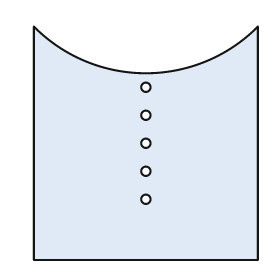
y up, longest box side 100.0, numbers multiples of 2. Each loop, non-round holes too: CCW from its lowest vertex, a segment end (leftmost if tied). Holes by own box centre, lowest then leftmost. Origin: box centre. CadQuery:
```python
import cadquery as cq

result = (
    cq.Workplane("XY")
    .moveTo(-48.0, -50.0)
    .lineTo(48.0, -50.0)
    .lineTo(48.0, 50.0)
    .threePointArc((0.0, 30.0), (-48.0, 50.0))
    .close()
    .moveTo(0.0, -24.0)
    .circle(2.0)
    .moveTo(0.0, -12.0)
    .circle(2.0)
    .moveTo(0.0, 0.0)
    .circle(2.0)
    .moveTo(0.0, 12.0)
    .circle(2.0)
    .moveTo(0.0, 24.0)
    .circle(2.0)
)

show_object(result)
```